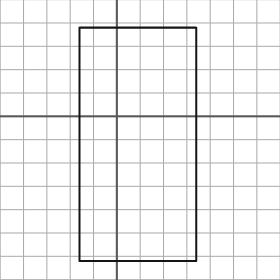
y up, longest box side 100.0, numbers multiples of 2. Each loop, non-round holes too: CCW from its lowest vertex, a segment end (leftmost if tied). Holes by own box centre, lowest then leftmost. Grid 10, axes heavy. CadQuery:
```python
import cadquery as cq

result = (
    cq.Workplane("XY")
    .moveTo(-16.0, -62.0)
    .lineTo(34.0, -62.0)
    .lineTo(34.0, 38.0)
    .lineTo(-16.0, 38.0)
    .close()
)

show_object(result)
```